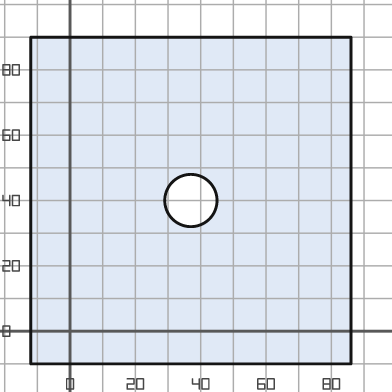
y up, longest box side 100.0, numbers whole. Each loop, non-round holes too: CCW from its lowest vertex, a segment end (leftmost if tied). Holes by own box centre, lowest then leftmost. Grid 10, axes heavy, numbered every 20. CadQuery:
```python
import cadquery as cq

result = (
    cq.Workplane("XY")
    .moveTo(-12.0, -10.0)
    .lineTo(86.0, -10.0)
    .lineTo(86.0, 90.0)
    .lineTo(-12.0, 90.0)
    .close()
    .moveTo(37.0, 40.0)
    .circle(8.0)
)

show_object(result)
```